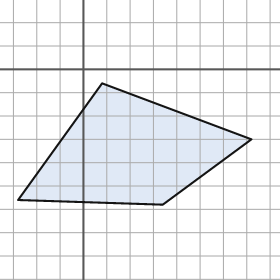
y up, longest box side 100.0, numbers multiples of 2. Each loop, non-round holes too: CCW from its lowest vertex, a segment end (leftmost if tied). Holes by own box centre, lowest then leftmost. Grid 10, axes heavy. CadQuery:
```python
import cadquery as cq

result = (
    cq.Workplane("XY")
    .moveTo(34.0, -58.0)
    .lineTo(72.0, -30.0)
    .lineTo(8.0, -6.0)
    .lineTo(-28.0, -56.0)
    .close()
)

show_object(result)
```